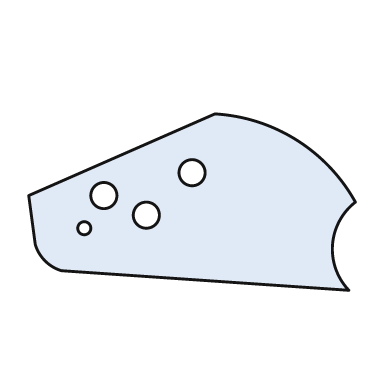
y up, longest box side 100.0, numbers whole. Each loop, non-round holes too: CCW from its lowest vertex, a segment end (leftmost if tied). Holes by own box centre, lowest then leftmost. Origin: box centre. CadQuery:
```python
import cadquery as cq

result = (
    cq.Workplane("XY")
    .moveTo(48.0, -27.0)
    .threePointArc((43.0, -13.0), (50.0, 0.0))
    .threePointArc((32.0, 19.0), (7.0, 27.0))
    .lineTo(-50.0, 2.0)
    .lineTo(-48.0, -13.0)
    .threePointArc((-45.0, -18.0), (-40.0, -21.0))
    .close()
    .moveTo(-33.0, -8.0)
    .circle(2.0)
    .moveTo(-14.0, -4.0)
    .circle(4.0)
    .moveTo(-27.0, 2.0)
    .circle(4.0)
    .moveTo(0.0, 9.0)
    .circle(4.0)
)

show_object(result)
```